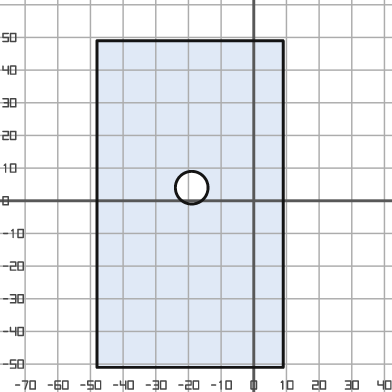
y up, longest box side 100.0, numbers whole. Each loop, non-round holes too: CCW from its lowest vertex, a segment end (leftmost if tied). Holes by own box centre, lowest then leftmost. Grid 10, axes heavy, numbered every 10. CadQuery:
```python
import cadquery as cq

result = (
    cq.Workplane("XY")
    .moveTo(-48.0, -51.0)
    .lineTo(9.0, -51.0)
    .lineTo(9.0, 49.0)
    .lineTo(-48.0, 49.0)
    .close()
    .moveTo(-19.0, 4.0)
    .circle(5.0)
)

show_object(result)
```